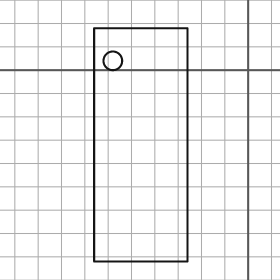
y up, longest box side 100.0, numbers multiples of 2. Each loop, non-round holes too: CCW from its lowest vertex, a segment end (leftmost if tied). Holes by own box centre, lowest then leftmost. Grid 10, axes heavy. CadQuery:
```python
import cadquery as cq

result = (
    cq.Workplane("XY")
    .moveTo(-66.0, -82.0)
    .lineTo(-26.0, -82.0)
    .lineTo(-26.0, 18.0)
    .lineTo(-66.0, 18.0)
    .close()
    .moveTo(-58.0, 4.0)
    .circle(4.0)
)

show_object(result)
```